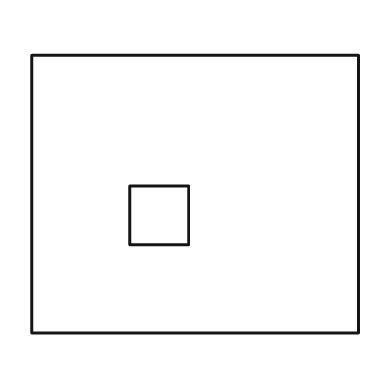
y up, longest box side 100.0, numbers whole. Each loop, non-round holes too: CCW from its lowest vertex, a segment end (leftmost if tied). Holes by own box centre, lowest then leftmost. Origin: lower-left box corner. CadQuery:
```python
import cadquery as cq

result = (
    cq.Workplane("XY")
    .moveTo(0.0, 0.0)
    .lineTo(100.0, 0.0)
    .lineTo(100.0, 85.0)
    .lineTo(0.0, 85.0)
    .close()
    .moveTo(30.0, 27.0)
    .lineTo(48.0, 27.0)
    .lineTo(48.0, 45.0)
    .lineTo(30.0, 45.0)
    .close()
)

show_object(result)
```